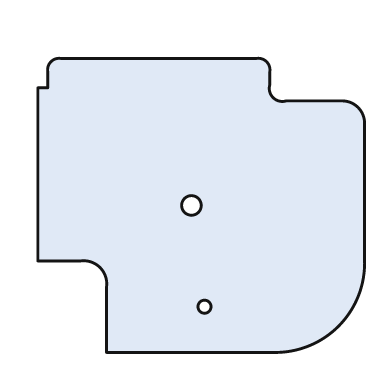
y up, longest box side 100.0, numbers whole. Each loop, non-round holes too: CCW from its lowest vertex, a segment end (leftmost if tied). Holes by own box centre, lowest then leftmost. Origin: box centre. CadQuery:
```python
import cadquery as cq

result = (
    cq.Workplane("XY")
    .moveTo(-29.0, -45.0)
    .lineTo(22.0, -45.0)
    .threePointArc((42.0, -37.0), (50.0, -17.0))
    .lineTo(50.0, 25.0)
    .threePointArc((48.0, 30.0), (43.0, 32.0))
    .lineTo(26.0, 32.0)
    .threePointArc((22.0, 33.0), (21.0, 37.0))
    .lineTo(21.0, 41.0)
    .threePointArc((20.0, 44.0), (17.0, 45.0))
    .lineTo(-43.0, 45.0)
    .threePointArc((-46.0, 44.0), (-47.0, 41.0))
    .lineTo(-47.0, 36.0)
    .lineTo(-50.0, 36.0)
    .lineTo(-50.0, -17.0)
    .lineTo(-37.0, -17.0)
    .threePointArc((-31.0, -19.0), (-29.0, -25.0))
    .close()
    .moveTo(1.0, -31.0)
    .circle(2.0)
    .moveTo(-3.0, 0.0)
    .circle(3.0)
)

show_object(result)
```